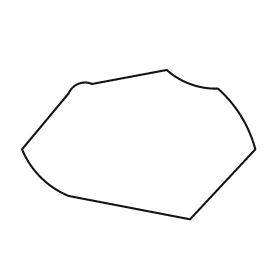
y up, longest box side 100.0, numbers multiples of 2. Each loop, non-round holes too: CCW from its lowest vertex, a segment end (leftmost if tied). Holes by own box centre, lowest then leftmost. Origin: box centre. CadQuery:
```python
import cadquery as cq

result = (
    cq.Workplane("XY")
    .moveTo(22.0, -32.0)
    .lineTo(50.0, -2.0)
    .threePointArc((44.0, 12.0), (34.0, 24.0))
    .threePointArc((22.0, 26.0), (12.0, 32.0))
    .lineTo(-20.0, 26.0)
    .threePointArc((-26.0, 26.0), (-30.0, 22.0))
    .lineTo(-50.0, -2.0)
    .threePointArc((-42.0, -14.0), (-30.0, -22.0))
    .close()
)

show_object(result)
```